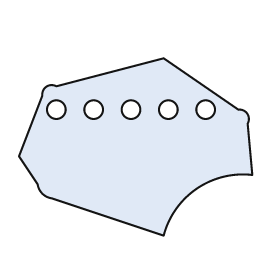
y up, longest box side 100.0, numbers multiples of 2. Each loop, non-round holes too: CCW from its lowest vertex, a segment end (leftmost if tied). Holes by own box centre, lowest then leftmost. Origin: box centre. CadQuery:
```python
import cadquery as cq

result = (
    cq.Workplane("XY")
    .moveTo(12.0, -38.0)
    .threePointArc((26.0, -18.0), (50.0, -12.0))
    .lineTo(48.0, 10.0)
    .threePointArc((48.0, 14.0), (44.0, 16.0))
    .lineTo(12.0, 38.0)
    .lineTo(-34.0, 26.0)
    .threePointArc((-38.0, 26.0), (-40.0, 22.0))
    .lineTo(-50.0, -4.0)
    .lineTo(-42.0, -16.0)
    .threePointArc((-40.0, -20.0), (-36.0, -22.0))
    .close()
    .moveTo(-34.0, 16.0)
    .circle(4.0)
    .moveTo(-18.0, 16.0)
    .circle(4.0)
    .moveTo(-2.0, 16.0)
    .circle(4.0)
    .moveTo(14.0, 16.0)
    .circle(4.0)
    .moveTo(30.0, 16.0)
    .circle(4.0)
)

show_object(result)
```